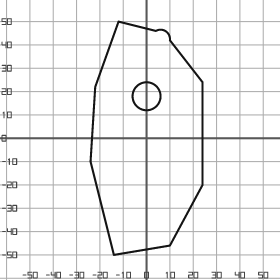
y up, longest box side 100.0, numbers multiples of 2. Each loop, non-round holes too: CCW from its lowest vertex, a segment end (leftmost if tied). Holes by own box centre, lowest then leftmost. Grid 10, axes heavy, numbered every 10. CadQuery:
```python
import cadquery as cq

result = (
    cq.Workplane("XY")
    .moveTo(-14.0, -50.0)
    .lineTo(10.0, -46.0)
    .lineTo(24.0, -20.0)
    .lineTo(24.0, 24.0)
    .lineTo(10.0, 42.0)
    .threePointArc((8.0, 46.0), (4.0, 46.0))
    .lineTo(-12.0, 50.0)
    .lineTo(-22.0, 22.0)
    .lineTo(-24.0, -10.0)
    .close()
    .moveTo(0.0, 18.0)
    .circle(6.0)
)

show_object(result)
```